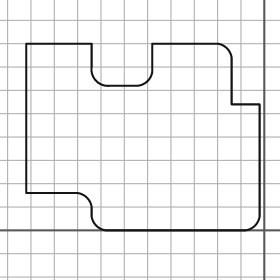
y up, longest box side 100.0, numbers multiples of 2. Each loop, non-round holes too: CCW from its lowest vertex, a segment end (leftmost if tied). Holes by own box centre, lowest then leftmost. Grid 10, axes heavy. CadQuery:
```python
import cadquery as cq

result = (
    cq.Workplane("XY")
    .moveTo(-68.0, 0.0)
    .lineTo(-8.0, 0.0)
    .threePointArc((-4.0, 2.0), (-2.0, 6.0))
    .lineTo(-2.0, 54.0)
    .lineTo(-14.0, 54.0)
    .lineTo(-14.0, 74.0)
    .threePointArc((-16.0, 78.0), (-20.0, 80.0))
    .lineTo(-48.0, 80.0)
    .lineTo(-48.0, 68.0)
    .threePointArc((-50.0, 64.0), (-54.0, 62.0))
    .lineTo(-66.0, 62.0)
    .threePointArc((-72.0, 64.0), (-74.0, 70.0))
    .lineTo(-74.0, 80.0)
    .lineTo(-102.0, 80.0)
    .lineTo(-102.0, 16.0)
    .lineTo(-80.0, 16.0)
    .threePointArc((-76.0, 14.0), (-74.0, 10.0))
    .lineTo(-74.0, 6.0)
    .threePointArc((-72.0, 2.0), (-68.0, 0.0))
    .close()
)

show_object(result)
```